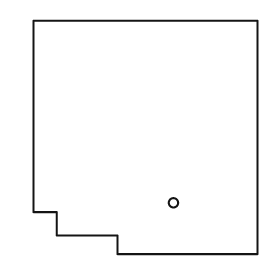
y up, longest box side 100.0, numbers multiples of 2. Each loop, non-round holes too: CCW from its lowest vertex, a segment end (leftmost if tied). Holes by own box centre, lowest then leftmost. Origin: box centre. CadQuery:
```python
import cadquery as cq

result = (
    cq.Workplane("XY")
    .moveTo(-12.0, -50.0)
    .lineTo(48.0, -50.0)
    .lineTo(48.0, 50.0)
    .lineTo(-48.0, 50.0)
    .lineTo(-48.0, -32.0)
    .lineTo(-38.0, -32.0)
    .lineTo(-38.0, -42.0)
    .lineTo(-12.0, -42.0)
    .close()
    .moveTo(12.0, -28.0)
    .circle(2.0)
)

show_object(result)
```